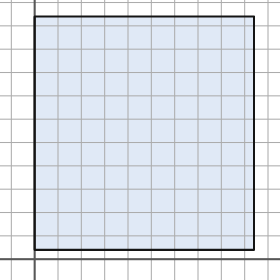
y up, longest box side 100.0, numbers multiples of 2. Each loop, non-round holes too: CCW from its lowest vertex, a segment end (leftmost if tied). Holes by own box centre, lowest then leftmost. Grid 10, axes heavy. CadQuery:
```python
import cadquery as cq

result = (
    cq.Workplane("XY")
    .moveTo(0.0, 4.0)
    .lineTo(94.0, 4.0)
    .lineTo(94.0, 104.0)
    .lineTo(0.0, 104.0)
    .close()
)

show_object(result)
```